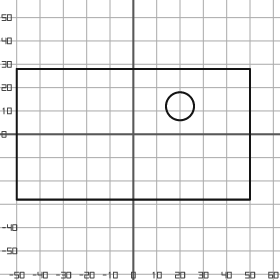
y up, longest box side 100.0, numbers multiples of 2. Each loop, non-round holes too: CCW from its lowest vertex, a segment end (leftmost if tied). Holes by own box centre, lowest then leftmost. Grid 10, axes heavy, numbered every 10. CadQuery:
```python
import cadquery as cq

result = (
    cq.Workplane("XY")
    .moveTo(-50.0, -28.0)
    .lineTo(50.0, -28.0)
    .lineTo(50.0, 28.0)
    .lineTo(-50.0, 28.0)
    .close()
    .moveTo(20.0, 12.0)
    .circle(6.0)
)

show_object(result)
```